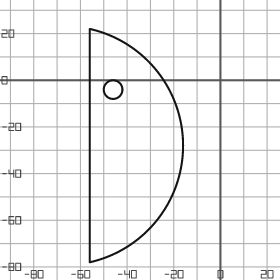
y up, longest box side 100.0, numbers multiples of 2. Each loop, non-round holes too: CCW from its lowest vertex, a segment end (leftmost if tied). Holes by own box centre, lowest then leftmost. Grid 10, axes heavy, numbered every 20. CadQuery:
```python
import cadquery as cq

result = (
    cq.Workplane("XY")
    .moveTo(-56.0, -78.0)
    .threePointArc((-16.0, -28.0), (-56.0, 22.0))
    .close()
    .moveTo(-46.0, -4.0)
    .circle(4.0)
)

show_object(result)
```